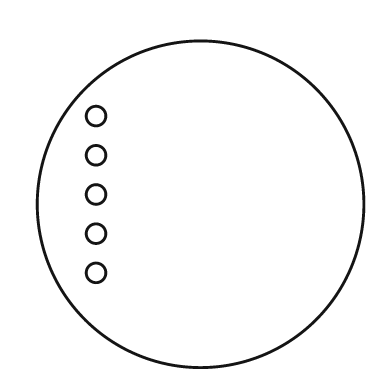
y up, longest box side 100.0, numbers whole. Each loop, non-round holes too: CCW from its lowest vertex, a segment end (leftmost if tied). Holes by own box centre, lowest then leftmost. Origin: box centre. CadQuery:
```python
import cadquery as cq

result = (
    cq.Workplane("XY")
    .moveTo(0.0, 0.0)
    .circle(50.0)
    .moveTo(-32.0, -21.0)
    .circle(3.0)
    .moveTo(-32.0, -9.0)
    .circle(3.0)
    .moveTo(-32.0, 3.0)
    .circle(3.0)
    .moveTo(-32.0, 15.0)
    .circle(3.0)
    .moveTo(-32.0, 27.0)
    .circle(3.0)
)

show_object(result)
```